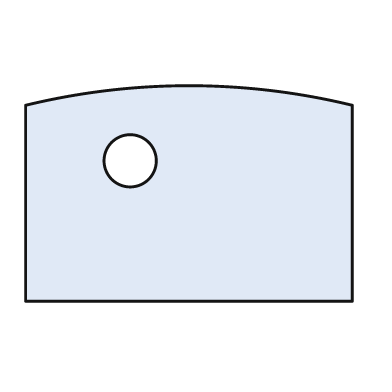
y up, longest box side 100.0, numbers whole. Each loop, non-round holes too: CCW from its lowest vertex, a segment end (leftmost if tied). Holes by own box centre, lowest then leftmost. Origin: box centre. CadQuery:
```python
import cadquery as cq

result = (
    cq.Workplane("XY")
    .moveTo(-50.0, -33.0)
    .lineTo(50.0, -33.0)
    .lineTo(50.0, 27.0)
    .threePointArc((0.0, 33.0), (-50.0, 27.0))
    .close()
    .moveTo(-18.0, 10.0)
    .circle(8.0)
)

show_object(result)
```